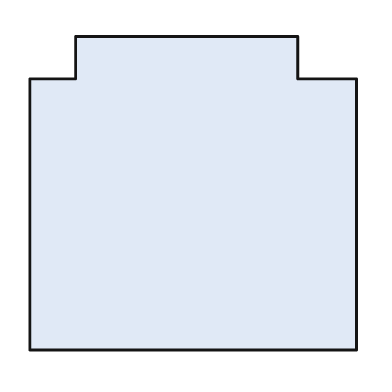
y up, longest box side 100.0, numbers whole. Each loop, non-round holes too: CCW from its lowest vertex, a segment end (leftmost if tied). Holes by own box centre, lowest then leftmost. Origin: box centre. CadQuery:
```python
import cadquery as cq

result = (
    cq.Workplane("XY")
    .moveTo(-50.0, -48.0)
    .lineTo(50.0, -48.0)
    .lineTo(50.0, 35.0)
    .lineTo(32.0, 35.0)
    .lineTo(32.0, 48.0)
    .lineTo(-36.0, 48.0)
    .lineTo(-36.0, 35.0)
    .lineTo(-50.0, 35.0)
    .close()
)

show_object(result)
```